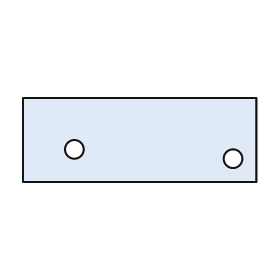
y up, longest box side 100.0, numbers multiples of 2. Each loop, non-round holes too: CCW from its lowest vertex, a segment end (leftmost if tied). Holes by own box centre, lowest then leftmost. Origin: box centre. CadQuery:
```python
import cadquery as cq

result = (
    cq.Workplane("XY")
    .moveTo(-50.0, -18.0)
    .lineTo(50.0, -18.0)
    .lineTo(50.0, 18.0)
    .lineTo(-50.0, 18.0)
    .close()
    .moveTo(40.0, -8.0)
    .circle(4.0)
    .moveTo(-28.0, -4.0)
    .circle(4.0)
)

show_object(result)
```